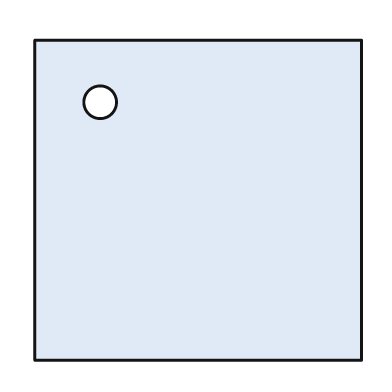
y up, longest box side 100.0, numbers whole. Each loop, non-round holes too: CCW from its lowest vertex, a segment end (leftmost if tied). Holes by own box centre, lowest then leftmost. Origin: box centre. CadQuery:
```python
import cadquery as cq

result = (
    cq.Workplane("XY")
    .moveTo(-50.0, -49.0)
    .lineTo(50.0, -49.0)
    .lineTo(50.0, 49.0)
    .lineTo(-50.0, 49.0)
    .close()
    .moveTo(-30.0, 30.0)
    .circle(5.0)
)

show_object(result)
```